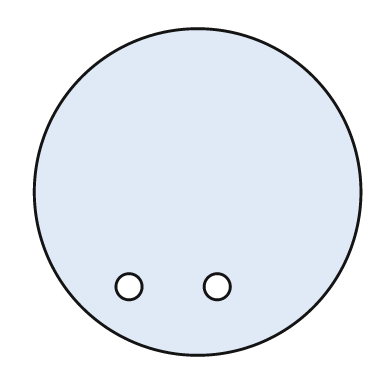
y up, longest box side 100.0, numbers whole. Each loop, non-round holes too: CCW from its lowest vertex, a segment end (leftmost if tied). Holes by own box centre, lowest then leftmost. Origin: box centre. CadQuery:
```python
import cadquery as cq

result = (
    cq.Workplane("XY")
    .moveTo(0.0, 0.0)
    .circle(50.0)
    .moveTo(-21.0, -29.0)
    .circle(4.0)
    .moveTo(6.0, -29.0)
    .circle(4.0)
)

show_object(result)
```